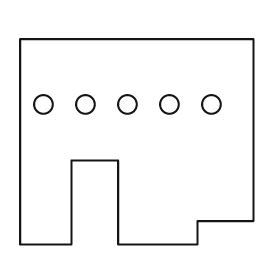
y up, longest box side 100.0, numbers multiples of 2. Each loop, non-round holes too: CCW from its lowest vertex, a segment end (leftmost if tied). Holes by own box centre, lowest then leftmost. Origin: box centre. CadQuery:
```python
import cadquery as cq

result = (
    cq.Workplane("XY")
    .moveTo(-50.0, -44.0)
    .lineTo(-28.0, -44.0)
    .lineTo(-28.0, -8.0)
    .lineTo(-8.0, -8.0)
    .lineTo(-8.0, -44.0)
    .lineTo(26.0, -44.0)
    .lineTo(26.0, -34.0)
    .lineTo(50.0, -34.0)
    .lineTo(50.0, 44.0)
    .lineTo(-50.0, 44.0)
    .close()
    .moveTo(-40.0, 16.0)
    .circle(4.0)
    .moveTo(-22.0, 16.0)
    .circle(4.0)
    .moveTo(-4.0, 16.0)
    .circle(4.0)
    .moveTo(14.0, 16.0)
    .circle(4.0)
    .moveTo(32.0, 16.0)
    .circle(4.0)
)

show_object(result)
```